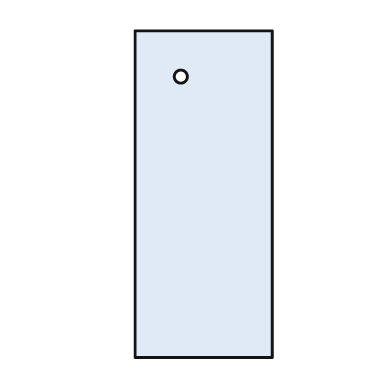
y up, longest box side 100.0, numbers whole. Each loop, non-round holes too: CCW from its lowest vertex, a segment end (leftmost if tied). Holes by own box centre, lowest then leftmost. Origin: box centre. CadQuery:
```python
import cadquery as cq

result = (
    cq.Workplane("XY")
    .moveTo(-21.0, -50.0)
    .lineTo(21.0, -50.0)
    .lineTo(21.0, 50.0)
    .lineTo(-21.0, 50.0)
    .close()
    .moveTo(-7.0, 36.0)
    .circle(2.0)
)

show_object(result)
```